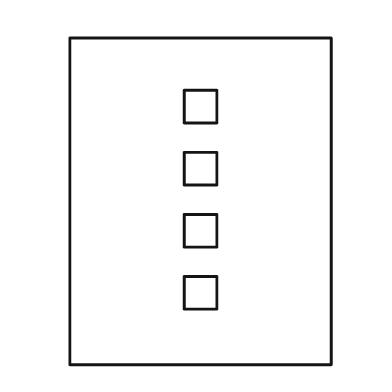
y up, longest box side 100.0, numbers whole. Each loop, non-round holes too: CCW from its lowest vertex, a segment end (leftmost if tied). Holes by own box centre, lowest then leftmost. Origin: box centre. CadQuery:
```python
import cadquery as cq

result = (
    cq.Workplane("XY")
    .moveTo(-40.0, -50.0)
    .lineTo(40.0, -50.0)
    .lineTo(40.0, 50.0)
    .lineTo(-40.0, 50.0)
    .close()
    .moveTo(-5.0, -33.0)
    .lineTo(5.0, -33.0)
    .lineTo(5.0, -23.0)
    .lineTo(-5.0, -23.0)
    .close()
    .moveTo(-5.0, -14.0)
    .lineTo(5.0, -14.0)
    .lineTo(5.0, -4.0)
    .lineTo(-5.0, -4.0)
    .close()
    .moveTo(-5.0, 5.0)
    .lineTo(5.0, 5.0)
    .lineTo(5.0, 15.0)
    .lineTo(-5.0, 15.0)
    .close()
    .moveTo(-5.0, 24.0)
    .lineTo(5.0, 24.0)
    .lineTo(5.0, 34.0)
    .lineTo(-5.0, 34.0)
    .close()
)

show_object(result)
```